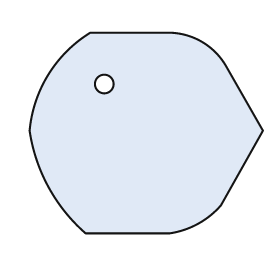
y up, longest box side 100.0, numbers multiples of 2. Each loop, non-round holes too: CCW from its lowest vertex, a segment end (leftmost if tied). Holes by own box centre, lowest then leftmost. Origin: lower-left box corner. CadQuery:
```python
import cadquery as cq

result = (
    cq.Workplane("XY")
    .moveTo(24.0, 0.0)
    .lineTo(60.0, 0.0)
    .threePointArc((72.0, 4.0), (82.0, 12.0))
    .lineTo(100.0, 44.0)
    .lineTo(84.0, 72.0)
    .threePointArc((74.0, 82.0), (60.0, 86.0))
    .lineTo(26.0, 86.0)
    .threePointArc((8.0, 68.0), (0.0, 44.0))
    .threePointArc((8.0, 20.0), (24.0, 0.0))
    .close()
    .moveTo(32.0, 64.0)
    .circle(4.0)
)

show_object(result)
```